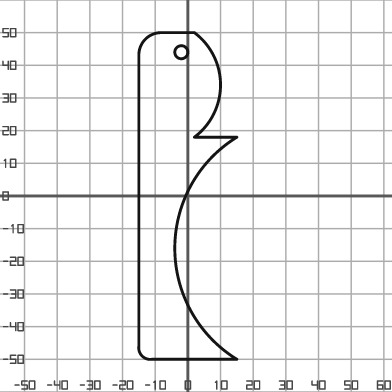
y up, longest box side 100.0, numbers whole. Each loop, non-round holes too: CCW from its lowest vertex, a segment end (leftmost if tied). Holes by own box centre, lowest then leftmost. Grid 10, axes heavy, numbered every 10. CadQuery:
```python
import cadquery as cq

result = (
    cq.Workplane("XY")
    .moveTo(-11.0, -50.0)
    .lineTo(15.0, -50.0)
    .threePointArc((-4.0, -16.0), (15.0, 18.0))
    .lineTo(2.0, 18.0)
    .threePointArc((10.0, 34.0), (2.0, 50.0))
    .lineTo(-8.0, 50.0)
    .threePointArc((-13.0, 48.0), (-15.0, 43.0))
    .lineTo(-15.0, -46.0)
    .threePointArc((-14.0, -49.0), (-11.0, -50.0))
    .close()
    .moveTo(-2.0, 44.0)
    .circle(2.0)
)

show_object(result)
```